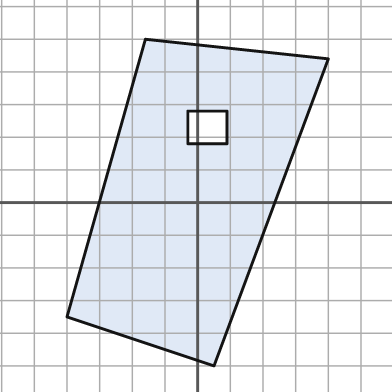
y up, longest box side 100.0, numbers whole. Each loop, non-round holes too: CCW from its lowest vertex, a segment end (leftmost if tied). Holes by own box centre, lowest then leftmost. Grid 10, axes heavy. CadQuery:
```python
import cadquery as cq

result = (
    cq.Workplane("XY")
    .moveTo(5.0, -50.0)
    .lineTo(40.0, 44.0)
    .lineTo(-16.0, 50.0)
    .lineTo(-40.0, -35.0)
    .close()
    .moveTo(-3.0, 18.0)
    .lineTo(9.0, 18.0)
    .lineTo(9.0, 28.0)
    .lineTo(-3.0, 28.0)
    .close()
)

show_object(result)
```